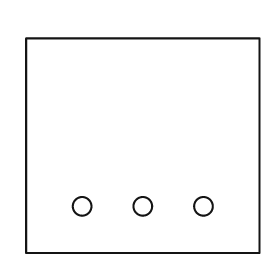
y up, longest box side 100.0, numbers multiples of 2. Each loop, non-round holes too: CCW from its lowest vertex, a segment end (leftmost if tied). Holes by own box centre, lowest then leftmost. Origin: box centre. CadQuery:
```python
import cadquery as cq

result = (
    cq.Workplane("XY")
    .moveTo(-50.0, -46.0)
    .lineTo(50.0, -46.0)
    .lineTo(50.0, 46.0)
    .lineTo(-50.0, 46.0)
    .close()
    .moveTo(-26.0, -26.0)
    .circle(4.0)
    .moveTo(0.0, -26.0)
    .circle(4.0)
    .moveTo(26.0, -26.0)
    .circle(4.0)
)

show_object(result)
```